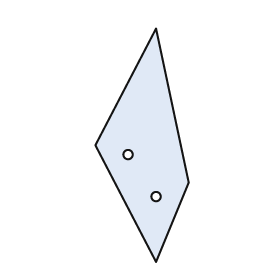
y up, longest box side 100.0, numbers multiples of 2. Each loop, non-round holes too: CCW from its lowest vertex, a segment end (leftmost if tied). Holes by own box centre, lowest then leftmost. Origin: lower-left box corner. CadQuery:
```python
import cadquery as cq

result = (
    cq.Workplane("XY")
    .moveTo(26.0, 0.0)
    .lineTo(40.0, 34.0)
    .lineTo(26.0, 100.0)
    .lineTo(0.0, 50.0)
    .close()
    .moveTo(26.0, 28.0)
    .circle(2.0)
    .moveTo(14.0, 46.0)
    .circle(2.0)
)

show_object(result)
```